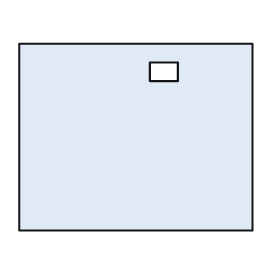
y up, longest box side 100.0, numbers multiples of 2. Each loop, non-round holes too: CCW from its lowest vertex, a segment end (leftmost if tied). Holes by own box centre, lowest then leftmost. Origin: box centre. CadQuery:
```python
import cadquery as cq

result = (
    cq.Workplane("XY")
    .moveTo(-50.0, -40.0)
    .lineTo(50.0, -40.0)
    .lineTo(50.0, 40.0)
    .lineTo(-50.0, 40.0)
    .close()
    .moveTo(6.0, 24.0)
    .lineTo(18.0, 24.0)
    .lineTo(18.0, 32.0)
    .lineTo(6.0, 32.0)
    .close()
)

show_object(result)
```